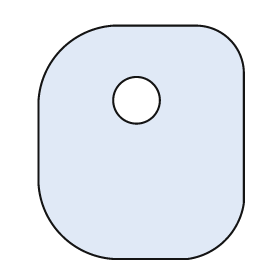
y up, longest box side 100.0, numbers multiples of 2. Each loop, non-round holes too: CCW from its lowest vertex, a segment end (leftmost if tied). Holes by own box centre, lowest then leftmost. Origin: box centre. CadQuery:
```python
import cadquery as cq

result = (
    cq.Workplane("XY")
    .moveTo(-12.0, -50.0)
    .lineTo(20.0, -50.0)
    .threePointArc((36.0, -42.0), (44.0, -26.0))
    .lineTo(44.0, 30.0)
    .threePointArc((38.0, 44.0), (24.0, 50.0))
    .lineTo(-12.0, 50.0)
    .threePointArc((-34.0, 40.0), (-44.0, 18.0))
    .lineTo(-44.0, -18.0)
    .threePointArc((-34.0, -40.0), (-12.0, -50.0))
    .close()
    .moveTo(-2.0, 18.0)
    .circle(10.0)
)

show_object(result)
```